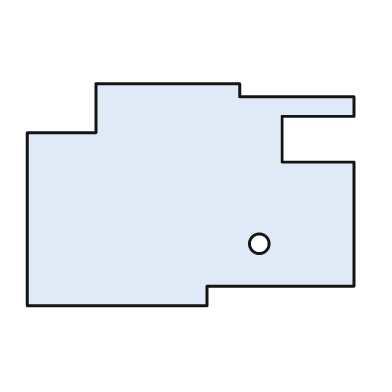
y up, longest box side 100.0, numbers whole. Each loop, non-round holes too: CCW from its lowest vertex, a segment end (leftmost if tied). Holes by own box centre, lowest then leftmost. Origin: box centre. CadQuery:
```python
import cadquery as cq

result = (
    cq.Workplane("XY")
    .moveTo(-50.0, -34.0)
    .lineTo(5.0, -34.0)
    .lineTo(5.0, -28.0)
    .lineTo(50.0, -28.0)
    .lineTo(50.0, 10.0)
    .lineTo(28.0, 10.0)
    .lineTo(28.0, 24.0)
    .lineTo(50.0, 24.0)
    .lineTo(50.0, 30.0)
    .lineTo(15.0, 30.0)
    .lineTo(15.0, 34.0)
    .lineTo(-29.0, 34.0)
    .lineTo(-29.0, 19.0)
    .lineTo(-50.0, 19.0)
    .close()
    .moveTo(21.0, -15.0)
    .circle(3.0)
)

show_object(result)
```